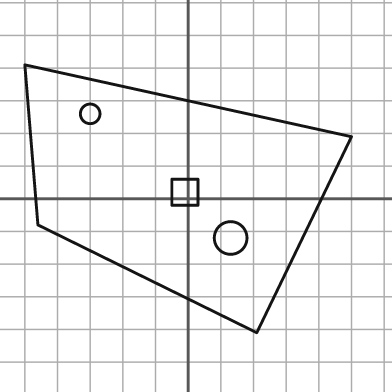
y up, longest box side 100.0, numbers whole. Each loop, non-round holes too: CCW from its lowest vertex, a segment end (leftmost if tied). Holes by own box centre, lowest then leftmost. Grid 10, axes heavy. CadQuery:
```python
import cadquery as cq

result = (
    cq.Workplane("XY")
    .moveTo(21.0, -41.0)
    .lineTo(50.0, 19.0)
    .lineTo(-50.0, 41.0)
    .lineTo(-46.0, -8.0)
    .close()
    .moveTo(13.0, -12.0)
    .circle(5.0)
    .moveTo(-5.0, -2.0)
    .lineTo(3.0, -2.0)
    .lineTo(3.0, 6.0)
    .lineTo(-5.0, 6.0)
    .close()
    .moveTo(-30.0, 26.0)
    .circle(3.0)
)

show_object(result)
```